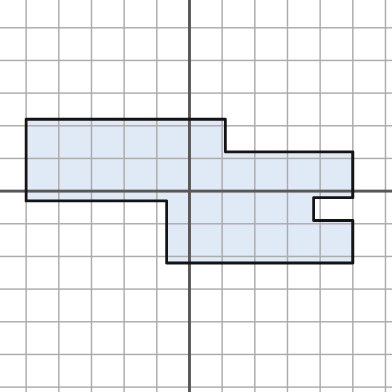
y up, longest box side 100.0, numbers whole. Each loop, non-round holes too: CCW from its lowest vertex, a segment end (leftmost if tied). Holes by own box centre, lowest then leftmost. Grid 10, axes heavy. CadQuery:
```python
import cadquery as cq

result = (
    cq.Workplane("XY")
    .moveTo(-7.0, -22.0)
    .lineTo(50.0, -22.0)
    .lineTo(50.0, -9.0)
    .lineTo(38.0, -9.0)
    .lineTo(38.0, -2.0)
    .lineTo(50.0, -2.0)
    .lineTo(50.0, 12.0)
    .lineTo(11.0, 12.0)
    .lineTo(11.0, 22.0)
    .lineTo(-50.0, 22.0)
    .lineTo(-50.0, -3.0)
    .lineTo(-7.0, -3.0)
    .close()
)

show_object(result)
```